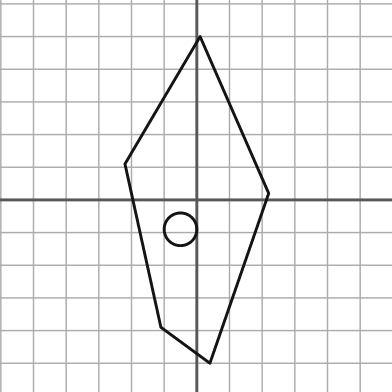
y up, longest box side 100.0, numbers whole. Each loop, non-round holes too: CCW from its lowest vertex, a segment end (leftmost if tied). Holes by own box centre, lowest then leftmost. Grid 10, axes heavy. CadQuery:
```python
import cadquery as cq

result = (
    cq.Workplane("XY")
    .moveTo(4.0, -50.0)
    .lineTo(22.0, 2.0)
    .lineTo(1.0, 50.0)
    .lineTo(-22.0, 11.0)
    .lineTo(-11.0, -39.0)
    .close()
    .moveTo(-5.0, -9.0)
    .circle(5.0)
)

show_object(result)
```